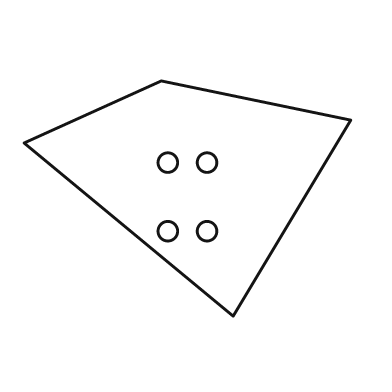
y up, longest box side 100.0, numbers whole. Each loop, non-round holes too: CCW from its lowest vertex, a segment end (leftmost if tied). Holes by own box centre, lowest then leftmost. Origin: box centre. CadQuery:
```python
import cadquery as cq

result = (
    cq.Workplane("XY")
    .moveTo(14.0, -36.0)
    .lineTo(50.0, 24.0)
    .lineTo(-8.0, 36.0)
    .lineTo(-50.0, 17.0)
    .close()
    .moveTo(-6.0, -10.0)
    .circle(3.0)
    .moveTo(6.0, -10.0)
    .circle(3.0)
    .moveTo(-6.0, 11.0)
    .circle(3.0)
    .moveTo(6.0, 11.0)
    .circle(3.0)
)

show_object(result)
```